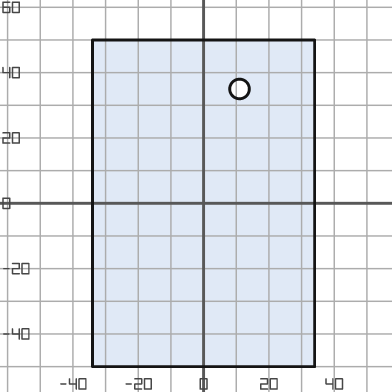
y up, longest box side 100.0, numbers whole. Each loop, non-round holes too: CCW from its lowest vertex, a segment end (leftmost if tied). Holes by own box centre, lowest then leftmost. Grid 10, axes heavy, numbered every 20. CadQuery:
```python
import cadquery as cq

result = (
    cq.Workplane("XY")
    .moveTo(-34.0, -50.0)
    .lineTo(34.0, -50.0)
    .lineTo(34.0, 50.0)
    .lineTo(-34.0, 50.0)
    .close()
    .moveTo(11.0, 35.0)
    .circle(3.0)
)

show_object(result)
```